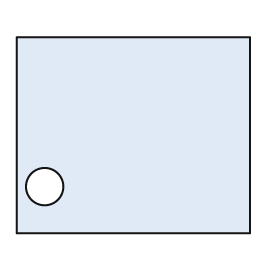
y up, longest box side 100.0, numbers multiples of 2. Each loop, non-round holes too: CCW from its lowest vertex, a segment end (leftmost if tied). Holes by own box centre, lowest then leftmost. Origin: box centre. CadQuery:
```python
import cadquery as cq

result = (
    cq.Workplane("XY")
    .moveTo(-50.0, -42.0)
    .lineTo(50.0, -42.0)
    .lineTo(50.0, 42.0)
    .lineTo(-50.0, 42.0)
    .close()
    .moveTo(-38.0, -22.0)
    .circle(8.0)
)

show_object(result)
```